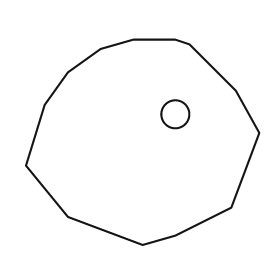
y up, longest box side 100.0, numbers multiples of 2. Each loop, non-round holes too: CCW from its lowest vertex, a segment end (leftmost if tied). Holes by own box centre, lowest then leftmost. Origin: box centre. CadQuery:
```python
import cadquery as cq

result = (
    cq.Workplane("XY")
    .moveTo(0.0, -44.0)
    .lineTo(14.0, -40.0)
    .lineTo(38.0, -28.0)
    .lineTo(50.0, 4.0)
    .lineTo(40.0, 22.0)
    .lineTo(20.0, 42.0)
    .lineTo(14.0, 44.0)
    .lineTo(-4.0, 44.0)
    .lineTo(-18.0, 40.0)
    .lineTo(-32.0, 30.0)
    .lineTo(-42.0, 16.0)
    .lineTo(-50.0, -10.0)
    .lineTo(-32.0, -32.0)
    .close()
    .moveTo(14.0, 12.0)
    .circle(6.0)
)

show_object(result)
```